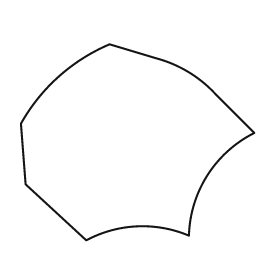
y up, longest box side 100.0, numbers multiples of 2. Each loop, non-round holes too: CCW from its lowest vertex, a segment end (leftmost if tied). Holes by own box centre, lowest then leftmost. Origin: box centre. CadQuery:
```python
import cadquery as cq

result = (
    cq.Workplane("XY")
    .moveTo(-22.0, -42.0)
    .threePointArc((0.0, -36.0), (22.0, -40.0))
    .threePointArc((30.0, -14.0), (50.0, 4.0))
    .lineTo(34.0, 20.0)
    .threePointArc((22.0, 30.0), (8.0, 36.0))
    .lineTo(-12.0, 42.0)
    .threePointArc((-34.0, 28.0), (-50.0, 8.0))
    .lineTo(-48.0, -18.0)
    .close()
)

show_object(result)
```